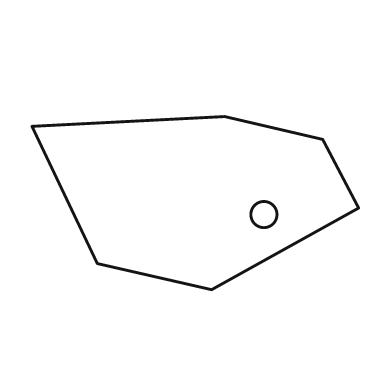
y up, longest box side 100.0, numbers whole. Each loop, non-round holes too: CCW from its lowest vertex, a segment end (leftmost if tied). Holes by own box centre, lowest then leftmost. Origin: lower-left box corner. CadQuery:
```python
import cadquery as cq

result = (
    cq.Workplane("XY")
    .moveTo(55.0, 0.0)
    .lineTo(100.0, 25.0)
    .lineTo(89.0, 46.0)
    .lineTo(59.0, 53.0)
    .lineTo(0.0, 50.0)
    .lineTo(20.0, 8.0)
    .close()
    .moveTo(71.0, 23.0)
    .circle(4.0)
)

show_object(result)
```